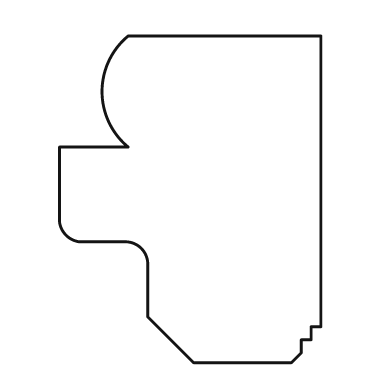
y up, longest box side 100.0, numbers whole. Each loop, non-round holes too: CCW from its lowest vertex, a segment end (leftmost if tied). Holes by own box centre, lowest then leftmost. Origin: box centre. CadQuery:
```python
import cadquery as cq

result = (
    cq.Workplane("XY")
    .moveTo(1.0, -50.0)
    .lineTo(31.0, -50.0)
    .lineTo(34.0, -47.0)
    .lineTo(34.0, -43.0)
    .lineTo(37.0, -43.0)
    .lineTo(37.0, -39.0)
    .lineTo(40.0, -39.0)
    .lineTo(40.0, 50.0)
    .lineTo(-19.0, 50.0)
    .threePointArc((-27.0, 33.0), (-19.0, 16.0))
    .lineTo(-40.0, 16.0)
    .lineTo(-40.0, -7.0)
    .threePointArc((-38.0, -11.0), (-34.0, -13.0))
    .lineTo(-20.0, -13.0)
    .threePointArc((-15.0, -15.0), (-13.0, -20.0))
    .lineTo(-13.0, -36.0)
    .close()
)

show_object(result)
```